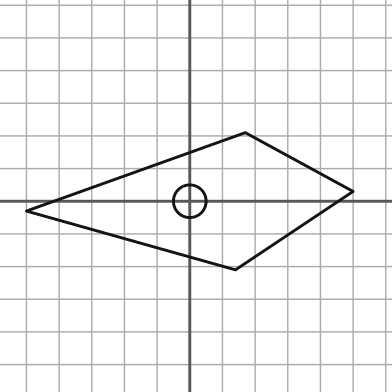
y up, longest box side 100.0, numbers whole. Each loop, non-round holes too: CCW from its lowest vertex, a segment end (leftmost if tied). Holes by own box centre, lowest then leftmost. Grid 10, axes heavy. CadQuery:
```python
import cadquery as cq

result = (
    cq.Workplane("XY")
    .moveTo(14.0, -21.0)
    .lineTo(50.0, 3.0)
    .lineTo(17.0, 21.0)
    .lineTo(-50.0, -3.0)
    .close()
    .moveTo(0.0, 0.0)
    .circle(5.0)
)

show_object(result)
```